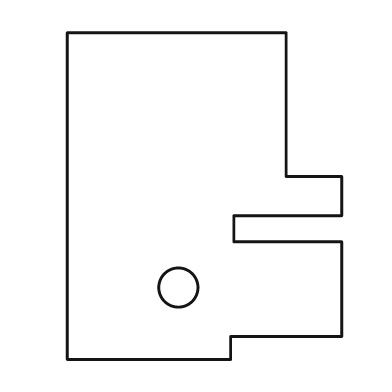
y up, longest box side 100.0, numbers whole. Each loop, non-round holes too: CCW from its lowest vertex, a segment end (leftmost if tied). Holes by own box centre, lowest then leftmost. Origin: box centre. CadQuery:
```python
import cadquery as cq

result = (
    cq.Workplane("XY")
    .moveTo(-42.0, -50.0)
    .lineTo(8.0, -50.0)
    .lineTo(8.0, -43.0)
    .lineTo(42.0, -43.0)
    .lineTo(42.0, -14.0)
    .lineTo(9.0, -14.0)
    .lineTo(9.0, -6.0)
    .lineTo(42.0, -6.0)
    .lineTo(42.0, 6.0)
    .lineTo(25.0, 6.0)
    .lineTo(25.0, 50.0)
    .lineTo(-42.0, 50.0)
    .close()
    .moveTo(-8.0, -28.0)
    .circle(6.0)
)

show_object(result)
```